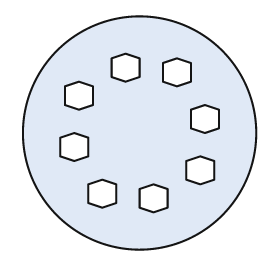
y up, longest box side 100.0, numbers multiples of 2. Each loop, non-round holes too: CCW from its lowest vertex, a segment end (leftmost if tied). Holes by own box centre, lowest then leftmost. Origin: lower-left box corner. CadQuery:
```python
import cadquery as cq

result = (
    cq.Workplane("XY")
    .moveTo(50.0, 50.0)
    .circle(50.0)
    .moveTo(56.0, 16.0)
    .lineTo(62.0, 18.0)
    .lineTo(62.0, 26.0)
    .lineTo(56.0, 28.0)
    .lineTo(50.0, 26.0)
    .lineTo(50.0, 18.0)
    .close()
    .moveTo(34.0, 18.0)
    .lineTo(40.0, 20.0)
    .lineTo(40.0, 28.0)
    .lineTo(34.0, 30.0)
    .lineTo(28.0, 28.0)
    .lineTo(28.0, 20.0)
    .close()
    .moveTo(76.0, 28.0)
    .lineTo(82.0, 30.0)
    .lineTo(82.0, 38.0)
    .lineTo(76.0, 40.0)
    .lineTo(70.0, 38.0)
    .lineTo(70.0, 30.0)
    .close()
    .moveTo(22.0, 38.0)
    .lineTo(28.0, 40.0)
    .lineTo(28.0, 48.0)
    .lineTo(22.0, 50.0)
    .lineTo(16.0, 48.0)
    .lineTo(16.0, 40.0)
    .close()
    .moveTo(78.0, 50.0)
    .lineTo(84.0, 52.0)
    .lineTo(84.0, 60.0)
    .lineTo(78.0, 62.0)
    .lineTo(72.0, 60.0)
    .lineTo(72.0, 52.0)
    .close()
    .moveTo(24.0, 60.0)
    .lineTo(30.0, 62.0)
    .lineTo(30.0, 70.0)
    .lineTo(24.0, 72.0)
    .lineTo(18.0, 70.0)
    .lineTo(18.0, 62.0)
    .close()
    .moveTo(66.0, 70.0)
    .lineTo(72.0, 72.0)
    .lineTo(72.0, 80.0)
    .lineTo(66.0, 82.0)
    .lineTo(60.0, 80.0)
    .lineTo(60.0, 72.0)
    .close()
    .moveTo(44.0, 72.0)
    .lineTo(50.0, 74.0)
    .lineTo(50.0, 82.0)
    .lineTo(44.0, 84.0)
    .lineTo(38.0, 82.0)
    .lineTo(38.0, 74.0)
    .close()
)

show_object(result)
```